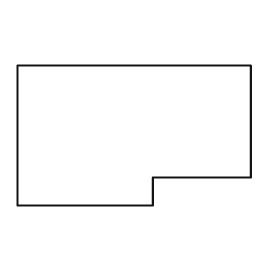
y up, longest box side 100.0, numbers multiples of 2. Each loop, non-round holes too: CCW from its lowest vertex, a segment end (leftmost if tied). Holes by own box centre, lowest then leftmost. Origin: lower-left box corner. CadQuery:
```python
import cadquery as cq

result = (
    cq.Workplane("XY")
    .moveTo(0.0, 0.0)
    .lineTo(58.0, 0.0)
    .lineTo(58.0, 12.0)
    .lineTo(100.0, 12.0)
    .lineTo(100.0, 60.0)
    .lineTo(0.0, 60.0)
    .close()
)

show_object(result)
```